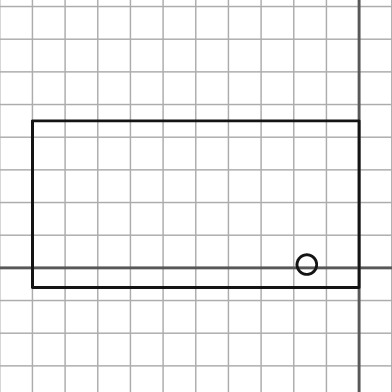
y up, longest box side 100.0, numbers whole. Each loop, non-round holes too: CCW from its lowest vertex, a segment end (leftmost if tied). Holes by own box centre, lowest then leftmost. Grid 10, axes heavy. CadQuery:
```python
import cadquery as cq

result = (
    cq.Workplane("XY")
    .moveTo(-100.0, -6.0)
    .lineTo(0.0, -6.0)
    .lineTo(0.0, 45.0)
    .lineTo(-100.0, 45.0)
    .close()
    .moveTo(-16.0, 1.0)
    .circle(3.0)
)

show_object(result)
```